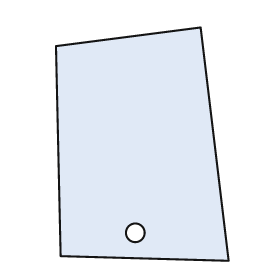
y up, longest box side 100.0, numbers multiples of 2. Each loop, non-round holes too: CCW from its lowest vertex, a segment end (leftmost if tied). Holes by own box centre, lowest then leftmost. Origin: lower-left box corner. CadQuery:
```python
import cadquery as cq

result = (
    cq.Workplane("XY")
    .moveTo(74.0, 0.0)
    .lineTo(62.0, 100.0)
    .lineTo(0.0, 92.0)
    .lineTo(2.0, 2.0)
    .close()
    .moveTo(34.0, 12.0)
    .circle(4.0)
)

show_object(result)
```